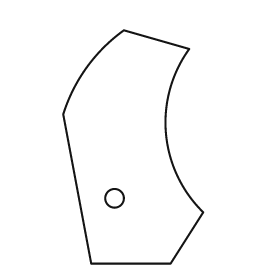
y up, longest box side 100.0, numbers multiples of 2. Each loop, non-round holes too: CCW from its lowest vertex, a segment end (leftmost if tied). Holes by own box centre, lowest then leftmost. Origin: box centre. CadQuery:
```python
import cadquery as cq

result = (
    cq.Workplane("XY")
    .moveTo(-18.0, -50.0)
    .lineTo(16.0, -50.0)
    .lineTo(30.0, -28.0)
    .threePointArc((14.0, 6.0), (24.0, 42.0))
    .lineTo(-4.0, 50.0)
    .threePointArc((-20.0, 34.0), (-30.0, 14.0))
    .close()
    .moveTo(-8.0, -22.0)
    .circle(4.0)
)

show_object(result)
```